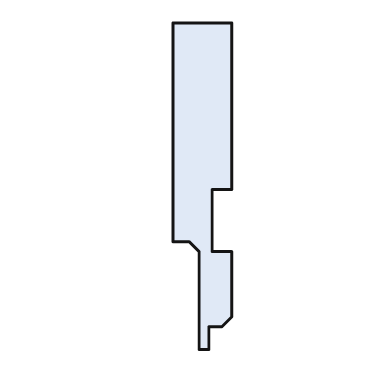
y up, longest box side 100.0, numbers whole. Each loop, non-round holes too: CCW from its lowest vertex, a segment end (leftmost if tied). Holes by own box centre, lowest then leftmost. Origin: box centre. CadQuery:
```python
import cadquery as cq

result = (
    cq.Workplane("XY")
    .moveTo(-1.0, -50.0)
    .lineTo(2.0, -50.0)
    .lineTo(2.0, -43.0)
    .lineTo(6.0, -43.0)
    .lineTo(9.0, -40.0)
    .lineTo(9.0, -20.0)
    .lineTo(3.0, -20.0)
    .lineTo(3.0, -1.0)
    .lineTo(9.0, -1.0)
    .lineTo(9.0, 50.0)
    .lineTo(-9.0, 50.0)
    .lineTo(-9.0, -17.0)
    .lineTo(-4.0, -17.0)
    .lineTo(-1.0, -20.0)
    .close()
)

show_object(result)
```